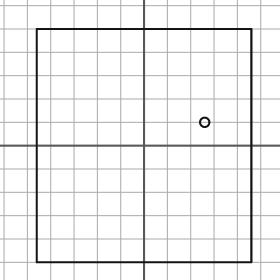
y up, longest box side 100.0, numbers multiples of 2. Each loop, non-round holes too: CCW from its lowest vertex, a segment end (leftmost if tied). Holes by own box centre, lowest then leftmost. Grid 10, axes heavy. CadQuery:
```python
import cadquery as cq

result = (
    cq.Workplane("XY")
    .moveTo(-46.0, -50.0)
    .lineTo(46.0, -50.0)
    .lineTo(46.0, 50.0)
    .lineTo(-46.0, 50.0)
    .close()
    .moveTo(26.0, 10.0)
    .circle(2.0)
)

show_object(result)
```